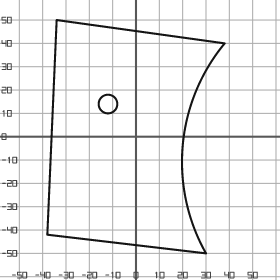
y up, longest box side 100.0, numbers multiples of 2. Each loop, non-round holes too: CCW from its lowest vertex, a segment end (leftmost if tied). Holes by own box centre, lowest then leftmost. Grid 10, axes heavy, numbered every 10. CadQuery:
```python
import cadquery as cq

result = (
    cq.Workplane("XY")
    .moveTo(30.0, -50.0)
    .threePointArc((20.0, -4.0), (38.0, 40.0))
    .lineTo(-34.0, 50.0)
    .lineTo(-38.0, -42.0)
    .close()
    .moveTo(-12.0, 14.0)
    .circle(4.0)
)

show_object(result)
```